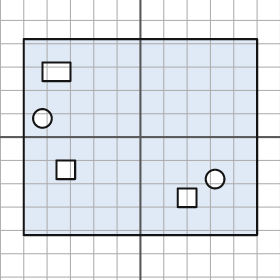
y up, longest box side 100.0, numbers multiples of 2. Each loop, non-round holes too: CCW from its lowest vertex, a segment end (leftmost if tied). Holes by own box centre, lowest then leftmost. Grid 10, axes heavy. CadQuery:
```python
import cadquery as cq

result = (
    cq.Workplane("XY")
    .moveTo(-50.0, -42.0)
    .lineTo(50.0, -42.0)
    .lineTo(50.0, 42.0)
    .lineTo(-50.0, 42.0)
    .close()
    .moveTo(16.0, -30.0)
    .lineTo(24.0, -30.0)
    .lineTo(24.0, -22.0)
    .lineTo(16.0, -22.0)
    .close()
    .moveTo(32.0, -18.0)
    .circle(4.0)
    .moveTo(-36.0, -18.0)
    .lineTo(-28.0, -18.0)
    .lineTo(-28.0, -10.0)
    .lineTo(-36.0, -10.0)
    .close()
    .moveTo(-42.0, 8.0)
    .circle(4.0)
    .moveTo(-42.0, 24.0)
    .lineTo(-30.0, 24.0)
    .lineTo(-30.0, 32.0)
    .lineTo(-42.0, 32.0)
    .close()
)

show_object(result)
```